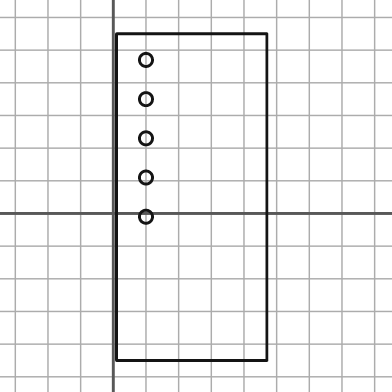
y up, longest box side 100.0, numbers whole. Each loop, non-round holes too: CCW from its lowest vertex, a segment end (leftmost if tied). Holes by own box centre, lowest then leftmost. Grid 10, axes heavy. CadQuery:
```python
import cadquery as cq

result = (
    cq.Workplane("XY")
    .moveTo(1.0, -45.0)
    .lineTo(47.0, -45.0)
    .lineTo(47.0, 55.0)
    .lineTo(1.0, 55.0)
    .close()
    .moveTo(10.0, -1.0)
    .circle(2.0)
    .moveTo(10.0, 11.0)
    .circle(2.0)
    .moveTo(10.0, 23.0)
    .circle(2.0)
    .moveTo(10.0, 35.0)
    .circle(2.0)
    .moveTo(10.0, 47.0)
    .circle(2.0)
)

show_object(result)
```